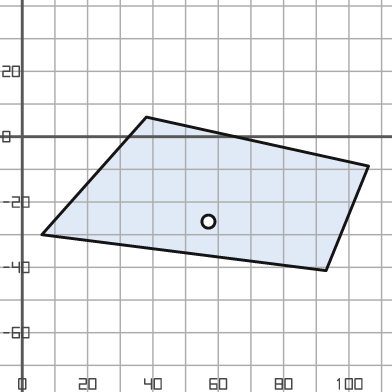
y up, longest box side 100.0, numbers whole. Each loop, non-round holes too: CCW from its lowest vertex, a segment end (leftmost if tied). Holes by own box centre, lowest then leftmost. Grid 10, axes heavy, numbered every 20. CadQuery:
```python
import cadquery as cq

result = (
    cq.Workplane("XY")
    .moveTo(93.0, -41.0)
    .lineTo(106.0, -9.0)
    .lineTo(38.0, 6.0)
    .lineTo(6.0, -30.0)
    .close()
    .moveTo(57.0, -26.0)
    .circle(2.0)
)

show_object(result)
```